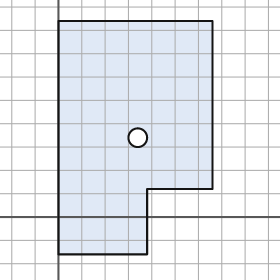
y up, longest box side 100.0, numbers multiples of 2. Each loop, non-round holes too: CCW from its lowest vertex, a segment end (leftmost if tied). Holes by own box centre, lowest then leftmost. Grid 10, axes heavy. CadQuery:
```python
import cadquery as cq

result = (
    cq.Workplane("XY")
    .moveTo(0.0, -16.0)
    .lineTo(38.0, -16.0)
    .lineTo(38.0, 12.0)
    .lineTo(66.0, 12.0)
    .lineTo(66.0, 84.0)
    .lineTo(0.0, 84.0)
    .close()
    .moveTo(34.0, 34.0)
    .circle(4.0)
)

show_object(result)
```